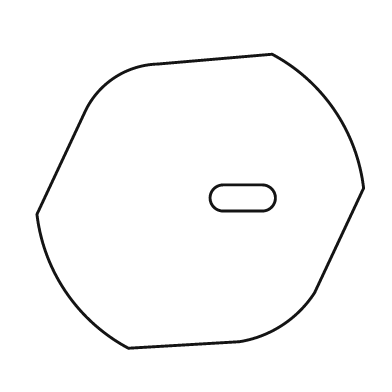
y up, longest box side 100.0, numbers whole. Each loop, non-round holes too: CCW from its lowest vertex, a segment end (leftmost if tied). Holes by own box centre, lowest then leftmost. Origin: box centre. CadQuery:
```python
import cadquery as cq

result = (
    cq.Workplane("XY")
    .moveTo(-22.0, -45.0)
    .lineTo(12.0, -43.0)
    .threePointArc((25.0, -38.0), (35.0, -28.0))
    .lineTo(50.0, 4.0)
    .threePointArc((41.0, 28.0), (22.0, 45.0))
    .lineTo(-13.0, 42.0)
    .threePointArc((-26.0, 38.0), (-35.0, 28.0))
    .lineTo(-50.0, -4.0)
    .threePointArc((-41.0, -28.0), (-22.0, -45.0))
    .close()
    .moveTo(7.0, -3.0)
    .lineTo(19.0, -3.0)
    .threePointArc((23.0, 1.0), (19.0, 5.0))
    .lineTo(7.0, 5.0)
    .threePointArc((3.0, 1.0), (7.0, -3.0))
    .close()
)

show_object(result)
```